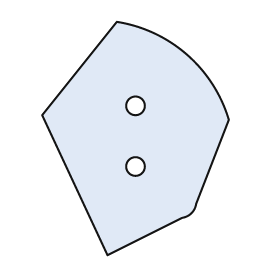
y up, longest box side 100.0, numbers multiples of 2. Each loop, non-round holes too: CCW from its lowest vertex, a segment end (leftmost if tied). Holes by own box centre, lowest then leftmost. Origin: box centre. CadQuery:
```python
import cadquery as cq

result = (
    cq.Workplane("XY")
    .moveTo(-12.0, -50.0)
    .lineTo(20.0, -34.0)
    .threePointArc((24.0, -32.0), (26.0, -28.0))
    .lineTo(40.0, 8.0)
    .threePointArc((22.0, 36.0), (-8.0, 50.0))
    .lineTo(-40.0, 10.0)
    .close()
    .moveTo(0.0, -12.0)
    .circle(4.0)
    .moveTo(0.0, 14.0)
    .circle(4.0)
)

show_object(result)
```